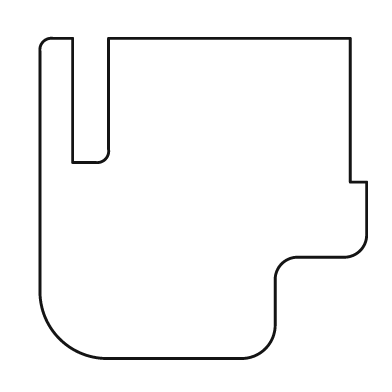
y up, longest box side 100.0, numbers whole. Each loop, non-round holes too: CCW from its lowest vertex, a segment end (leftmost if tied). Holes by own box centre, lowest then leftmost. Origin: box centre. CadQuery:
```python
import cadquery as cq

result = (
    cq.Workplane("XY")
    .moveTo(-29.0, -49.0)
    .lineTo(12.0, -49.0)
    .threePointArc((19.0, -46.0), (22.0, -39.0))
    .lineTo(22.0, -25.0)
    .threePointArc((24.0, -20.0), (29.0, -18.0))
    .lineTo(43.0, -18.0)
    .threePointArc((48.0, -16.0), (50.0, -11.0))
    .lineTo(50.0, 5.0)
    .lineTo(45.0, 5.0)
    .lineTo(45.0, 49.0)
    .lineTo(-29.0, 49.0)
    .lineTo(-29.0, 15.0)
    .threePointArc((-30.0, 12.0), (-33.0, 11.0))
    .lineTo(-40.0, 11.0)
    .lineTo(-40.0, 49.0)
    .lineTo(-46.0, 49.0)
    .threePointArc((-49.0, 48.0), (-50.0, 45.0))
    .lineTo(-50.0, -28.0)
    .threePointArc((-44.0, -43.0), (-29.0, -49.0))
    .close()
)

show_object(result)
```